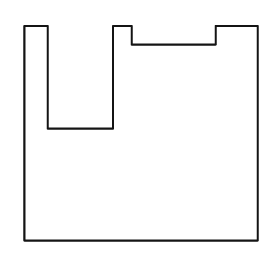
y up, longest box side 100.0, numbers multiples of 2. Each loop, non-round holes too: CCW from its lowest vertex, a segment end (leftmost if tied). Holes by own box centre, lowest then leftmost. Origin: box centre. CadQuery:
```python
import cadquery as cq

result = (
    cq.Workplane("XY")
    .moveTo(-50.0, -46.0)
    .lineTo(50.0, -46.0)
    .lineTo(50.0, 46.0)
    .lineTo(32.0, 46.0)
    .lineTo(32.0, 38.0)
    .lineTo(-4.0, 38.0)
    .lineTo(-4.0, 46.0)
    .lineTo(-12.0, 46.0)
    .lineTo(-12.0, 2.0)
    .lineTo(-40.0, 2.0)
    .lineTo(-40.0, 46.0)
    .lineTo(-50.0, 46.0)
    .close()
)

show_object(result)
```